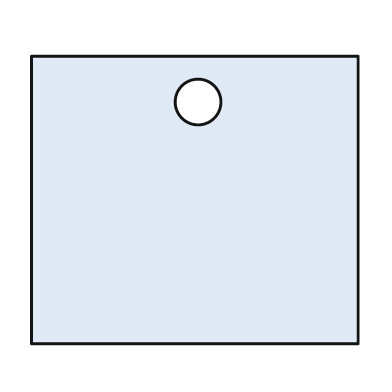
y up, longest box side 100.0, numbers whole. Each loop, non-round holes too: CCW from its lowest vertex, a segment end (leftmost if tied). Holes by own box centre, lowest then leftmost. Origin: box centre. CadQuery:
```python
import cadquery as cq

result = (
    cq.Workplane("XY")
    .moveTo(-50.0, -44.0)
    .lineTo(50.0, -44.0)
    .lineTo(50.0, 44.0)
    .lineTo(-50.0, 44.0)
    .close()
    .moveTo(1.0, 30.0)
    .circle(7.0)
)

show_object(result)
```